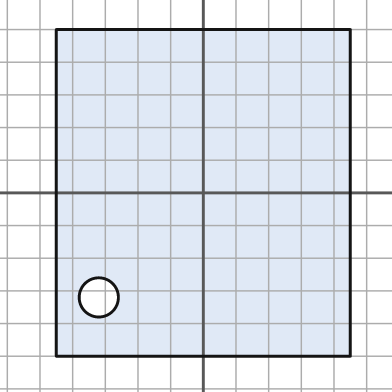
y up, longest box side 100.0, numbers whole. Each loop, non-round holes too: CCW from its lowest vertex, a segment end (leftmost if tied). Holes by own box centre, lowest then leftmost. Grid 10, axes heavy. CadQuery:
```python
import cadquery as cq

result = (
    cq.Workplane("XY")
    .moveTo(-45.0, -50.0)
    .lineTo(45.0, -50.0)
    .lineTo(45.0, 50.0)
    .lineTo(-45.0, 50.0)
    .close()
    .moveTo(-32.0, -32.0)
    .circle(6.0)
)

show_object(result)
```